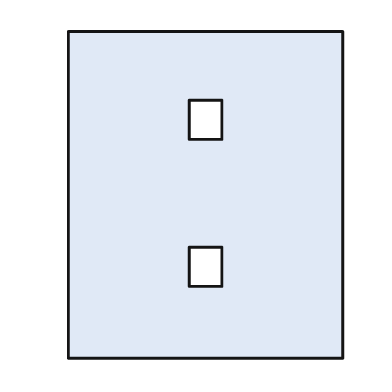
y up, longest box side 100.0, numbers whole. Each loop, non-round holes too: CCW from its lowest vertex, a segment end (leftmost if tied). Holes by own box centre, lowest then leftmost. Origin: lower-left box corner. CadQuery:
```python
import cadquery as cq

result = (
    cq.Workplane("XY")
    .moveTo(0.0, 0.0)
    .lineTo(84.0, 0.0)
    .lineTo(84.0, 100.0)
    .lineTo(0.0, 100.0)
    .close()
    .moveTo(37.0, 22.0)
    .lineTo(47.0, 22.0)
    .lineTo(47.0, 34.0)
    .lineTo(37.0, 34.0)
    .close()
    .moveTo(37.0, 67.0)
    .lineTo(47.0, 67.0)
    .lineTo(47.0, 79.0)
    .lineTo(37.0, 79.0)
    .close()
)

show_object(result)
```